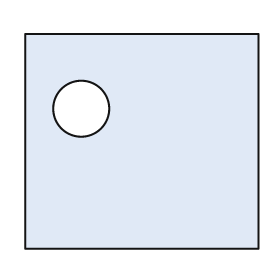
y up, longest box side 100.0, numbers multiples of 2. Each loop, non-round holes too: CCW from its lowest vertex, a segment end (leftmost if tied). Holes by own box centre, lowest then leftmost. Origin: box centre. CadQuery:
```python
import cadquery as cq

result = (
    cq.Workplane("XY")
    .moveTo(-50.0, -46.0)
    .lineTo(50.0, -46.0)
    .lineTo(50.0, 46.0)
    .lineTo(-50.0, 46.0)
    .close()
    .moveTo(-26.0, 14.0)
    .circle(12.0)
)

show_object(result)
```